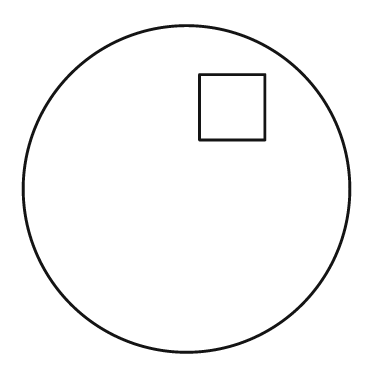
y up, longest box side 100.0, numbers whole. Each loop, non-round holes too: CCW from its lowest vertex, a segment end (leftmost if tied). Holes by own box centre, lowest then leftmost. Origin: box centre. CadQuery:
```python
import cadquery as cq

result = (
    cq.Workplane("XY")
    .moveTo(0.0, 0.0)
    .circle(50.0)
    .moveTo(4.0, 15.0)
    .lineTo(24.0, 15.0)
    .lineTo(24.0, 35.0)
    .lineTo(4.0, 35.0)
    .close()
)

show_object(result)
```